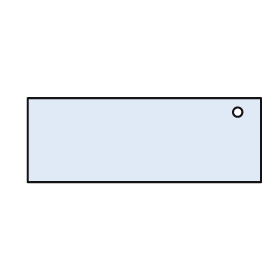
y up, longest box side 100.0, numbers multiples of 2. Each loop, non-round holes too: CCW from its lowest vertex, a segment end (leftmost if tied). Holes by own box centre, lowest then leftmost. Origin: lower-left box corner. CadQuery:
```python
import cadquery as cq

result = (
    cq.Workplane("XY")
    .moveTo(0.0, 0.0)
    .lineTo(100.0, 0.0)
    .lineTo(100.0, 36.0)
    .lineTo(0.0, 36.0)
    .close()
    .moveTo(90.0, 30.0)
    .circle(2.0)
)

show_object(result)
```